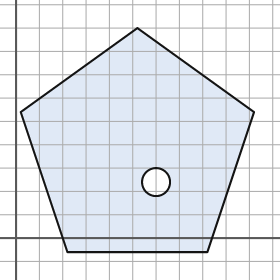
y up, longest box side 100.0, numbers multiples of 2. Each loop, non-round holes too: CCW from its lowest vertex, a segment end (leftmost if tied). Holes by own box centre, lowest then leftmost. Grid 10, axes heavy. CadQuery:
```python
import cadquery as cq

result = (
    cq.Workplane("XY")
    .moveTo(22.0, -6.0)
    .lineTo(82.0, -6.0)
    .lineTo(102.0, 54.0)
    .lineTo(52.0, 90.0)
    .lineTo(2.0, 54.0)
    .close()
    .moveTo(60.0, 24.0)
    .circle(6.0)
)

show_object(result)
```